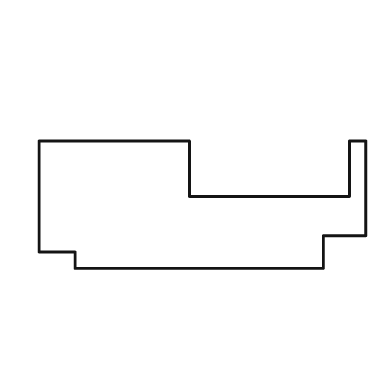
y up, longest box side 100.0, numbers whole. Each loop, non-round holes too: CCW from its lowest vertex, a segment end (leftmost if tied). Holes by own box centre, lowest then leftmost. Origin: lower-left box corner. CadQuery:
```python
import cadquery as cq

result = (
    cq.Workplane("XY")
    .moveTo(11.0, 0.0)
    .lineTo(87.0, 0.0)
    .lineTo(87.0, 10.0)
    .lineTo(100.0, 10.0)
    .lineTo(100.0, 39.0)
    .lineTo(95.0, 39.0)
    .lineTo(95.0, 22.0)
    .lineTo(46.0, 22.0)
    .lineTo(46.0, 39.0)
    .lineTo(0.0, 39.0)
    .lineTo(0.0, 5.0)
    .lineTo(11.0, 5.0)
    .close()
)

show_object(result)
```